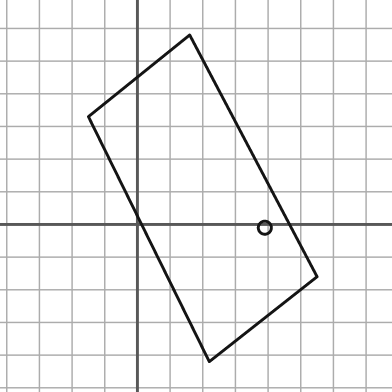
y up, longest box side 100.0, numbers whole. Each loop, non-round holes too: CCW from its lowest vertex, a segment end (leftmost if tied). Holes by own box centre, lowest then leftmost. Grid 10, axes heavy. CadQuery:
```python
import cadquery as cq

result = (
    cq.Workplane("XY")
    .moveTo(22.0, -42.0)
    .lineTo(55.0, -16.0)
    .lineTo(16.0, 58.0)
    .lineTo(-15.0, 33.0)
    .close()
    .moveTo(39.0, -1.0)
    .circle(2.0)
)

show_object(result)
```